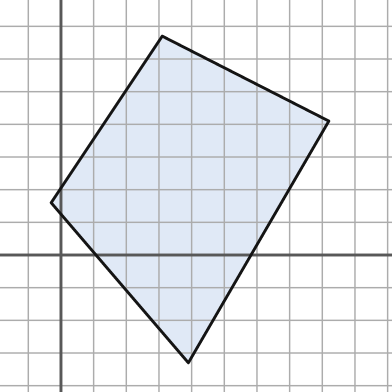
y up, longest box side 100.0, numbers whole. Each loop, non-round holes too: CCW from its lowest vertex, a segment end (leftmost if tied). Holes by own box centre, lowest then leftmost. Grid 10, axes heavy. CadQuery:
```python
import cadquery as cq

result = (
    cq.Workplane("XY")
    .moveTo(39.0, -33.0)
    .lineTo(82.0, 41.0)
    .lineTo(31.0, 67.0)
    .lineTo(-3.0, 16.0)
    .close()
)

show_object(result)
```